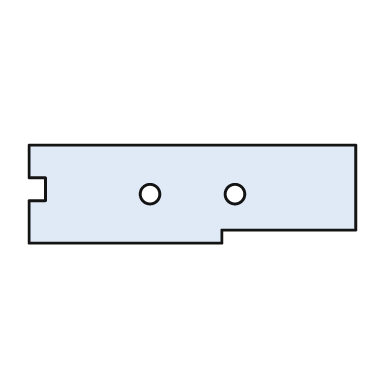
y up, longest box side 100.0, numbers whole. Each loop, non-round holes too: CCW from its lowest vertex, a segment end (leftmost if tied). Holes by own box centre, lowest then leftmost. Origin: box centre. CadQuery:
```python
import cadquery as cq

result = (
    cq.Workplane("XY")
    .moveTo(-50.0, -15.0)
    .lineTo(9.0, -15.0)
    .lineTo(9.0, -11.0)
    .lineTo(50.0, -11.0)
    .lineTo(50.0, 15.0)
    .lineTo(-50.0, 15.0)
    .lineTo(-50.0, 5.0)
    .lineTo(-45.0, 5.0)
    .lineTo(-45.0, -2.0)
    .lineTo(-50.0, -2.0)
    .close()
    .moveTo(-13.0, 0.0)
    .circle(3.0)
    .moveTo(13.0, 0.0)
    .circle(3.0)
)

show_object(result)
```